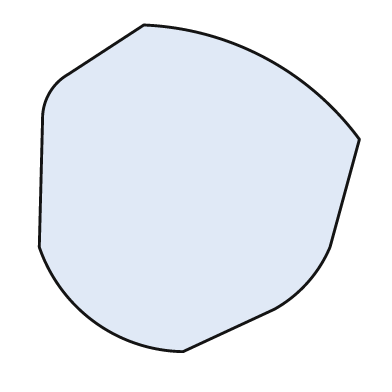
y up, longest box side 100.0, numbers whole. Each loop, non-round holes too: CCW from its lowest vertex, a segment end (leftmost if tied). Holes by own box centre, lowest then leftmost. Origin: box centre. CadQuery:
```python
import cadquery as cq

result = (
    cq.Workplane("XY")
    .moveTo(-5.0, -50.0)
    .lineTo(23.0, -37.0)
    .threePointArc((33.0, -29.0), (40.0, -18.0))
    .lineTo(49.0, 15.0)
    .threePointArc((20.0, 40.0), (-17.0, 50.0))
    .lineTo(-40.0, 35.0)
    .threePointArc((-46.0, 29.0), (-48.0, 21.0))
    .lineTo(-49.0, -18.0)
    .threePointArc((-32.0, -41.0), (-5.0, -50.0))
    .close()
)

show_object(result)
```